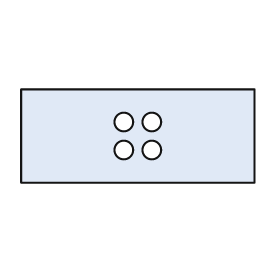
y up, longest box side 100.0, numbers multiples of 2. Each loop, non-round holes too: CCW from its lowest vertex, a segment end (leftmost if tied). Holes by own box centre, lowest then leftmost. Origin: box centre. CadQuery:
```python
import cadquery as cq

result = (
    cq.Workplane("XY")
    .moveTo(-50.0, -20.0)
    .lineTo(50.0, -20.0)
    .lineTo(50.0, 20.0)
    .lineTo(-50.0, 20.0)
    .close()
    .moveTo(-6.0, -6.0)
    .circle(4.0)
    .moveTo(6.0, -6.0)
    .circle(4.0)
    .moveTo(-6.0, 6.0)
    .circle(4.0)
    .moveTo(6.0, 6.0)
    .circle(4.0)
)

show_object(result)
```